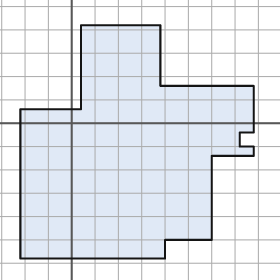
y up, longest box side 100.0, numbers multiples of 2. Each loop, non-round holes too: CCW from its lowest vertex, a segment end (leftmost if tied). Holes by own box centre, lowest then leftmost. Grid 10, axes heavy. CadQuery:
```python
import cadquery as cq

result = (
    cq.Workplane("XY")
    .moveTo(-22.0, -58.0)
    .lineTo(40.0, -58.0)
    .lineTo(40.0, -50.0)
    .lineTo(60.0, -50.0)
    .lineTo(60.0, -14.0)
    .lineTo(78.0, -14.0)
    .lineTo(78.0, -10.0)
    .lineTo(72.0, -10.0)
    .lineTo(72.0, -4.0)
    .lineTo(78.0, -4.0)
    .lineTo(78.0, 16.0)
    .lineTo(38.0, 16.0)
    .lineTo(38.0, 42.0)
    .lineTo(4.0, 42.0)
    .lineTo(4.0, 6.0)
    .lineTo(-22.0, 6.0)
    .close()
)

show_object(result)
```